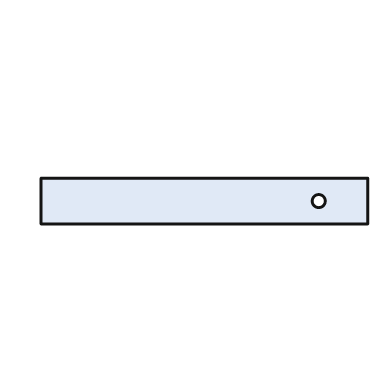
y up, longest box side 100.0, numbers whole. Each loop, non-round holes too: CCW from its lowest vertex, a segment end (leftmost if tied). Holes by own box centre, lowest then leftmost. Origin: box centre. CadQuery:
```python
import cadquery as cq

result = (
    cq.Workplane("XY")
    .moveTo(-50.0, -7.0)
    .lineTo(50.0, -7.0)
    .lineTo(50.0, 7.0)
    .lineTo(-50.0, 7.0)
    .close()
    .moveTo(35.0, 0.0)
    .circle(2.0)
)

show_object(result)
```